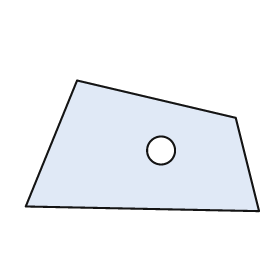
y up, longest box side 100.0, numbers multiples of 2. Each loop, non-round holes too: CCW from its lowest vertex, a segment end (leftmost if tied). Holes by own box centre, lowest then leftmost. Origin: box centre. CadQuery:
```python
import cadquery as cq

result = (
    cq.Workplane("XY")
    .moveTo(50.0, -28.0)
    .lineTo(40.0, 12.0)
    .lineTo(-28.0, 28.0)
    .lineTo(-50.0, -26.0)
    .close()
    .moveTo(8.0, -2.0)
    .circle(6.0)
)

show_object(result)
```